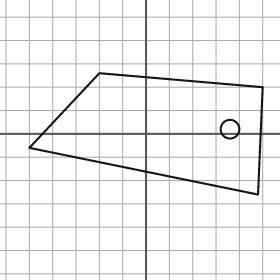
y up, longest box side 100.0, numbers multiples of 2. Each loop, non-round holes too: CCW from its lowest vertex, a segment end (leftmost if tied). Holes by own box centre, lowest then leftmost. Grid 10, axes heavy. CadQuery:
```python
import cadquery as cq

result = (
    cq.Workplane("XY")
    .moveTo(48.0, -26.0)
    .lineTo(50.0, 20.0)
    .lineTo(-20.0, 26.0)
    .lineTo(-50.0, -6.0)
    .close()
    .moveTo(36.0, 2.0)
    .circle(4.0)
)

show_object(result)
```